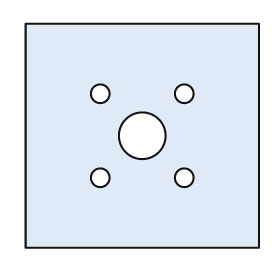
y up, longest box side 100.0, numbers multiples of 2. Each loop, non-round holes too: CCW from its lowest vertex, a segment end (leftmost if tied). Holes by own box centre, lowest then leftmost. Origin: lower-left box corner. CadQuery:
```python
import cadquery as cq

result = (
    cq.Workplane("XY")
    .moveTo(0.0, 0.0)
    .lineTo(100.0, 0.0)
    .lineTo(100.0, 96.0)
    .lineTo(0.0, 96.0)
    .close()
    .moveTo(32.0, 30.0)
    .circle(4.0)
    .moveTo(68.0, 30.0)
    .circle(4.0)
    .moveTo(50.0, 48.0)
    .circle(10.0)
    .moveTo(32.0, 66.0)
    .circle(4.0)
    .moveTo(68.0, 66.0)
    .circle(4.0)
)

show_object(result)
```